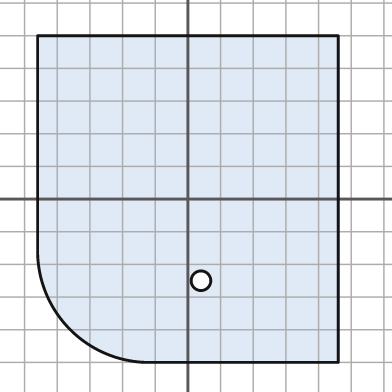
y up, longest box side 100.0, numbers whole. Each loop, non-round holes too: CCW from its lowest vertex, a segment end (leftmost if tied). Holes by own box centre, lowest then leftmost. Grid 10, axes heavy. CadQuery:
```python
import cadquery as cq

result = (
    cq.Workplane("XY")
    .moveTo(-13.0, -50.0)
    .lineTo(46.0, -50.0)
    .lineTo(46.0, 50.0)
    .lineTo(-46.0, 50.0)
    .lineTo(-46.0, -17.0)
    .threePointArc((-36.0, -40.0), (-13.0, -50.0))
    .close()
    .moveTo(4.0, -25.0)
    .circle(3.0)
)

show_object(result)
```